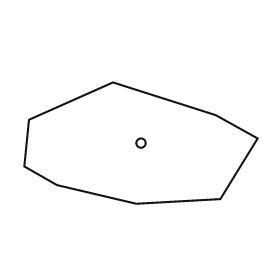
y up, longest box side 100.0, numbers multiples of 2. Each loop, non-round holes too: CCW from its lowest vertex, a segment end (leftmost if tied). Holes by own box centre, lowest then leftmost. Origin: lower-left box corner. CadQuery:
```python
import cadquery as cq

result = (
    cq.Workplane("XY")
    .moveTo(48.0, 0.0)
    .lineTo(84.0, 2.0)
    .lineTo(100.0, 28.0)
    .lineTo(82.0, 38.0)
    .lineTo(38.0, 52.0)
    .lineTo(2.0, 36.0)
    .lineTo(0.0, 16.0)
    .lineTo(14.0, 8.0)
    .close()
    .moveTo(50.0, 26.0)
    .circle(2.0)
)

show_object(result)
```